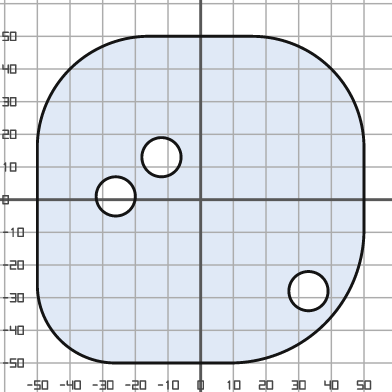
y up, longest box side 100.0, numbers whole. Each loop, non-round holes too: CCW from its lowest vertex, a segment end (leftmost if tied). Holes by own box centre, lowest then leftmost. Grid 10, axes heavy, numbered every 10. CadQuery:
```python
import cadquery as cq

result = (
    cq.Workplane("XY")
    .moveTo(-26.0, -50.0)
    .lineTo(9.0, -50.0)
    .threePointArc((38.0, -38.0), (50.0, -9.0))
    .lineTo(50.0, 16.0)
    .threePointArc((40.0, 40.0), (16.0, 50.0))
    .lineTo(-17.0, 50.0)
    .threePointArc((-40.0, 40.0), (-50.0, 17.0))
    .lineTo(-50.0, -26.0)
    .threePointArc((-43.0, -43.0), (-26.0, -50.0))
    .close()
    .moveTo(33.0, -28.0)
    .circle(6.0)
    .moveTo(-26.0, 1.0)
    .circle(6.0)
    .moveTo(-12.0, 13.0)
    .circle(6.0)
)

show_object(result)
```